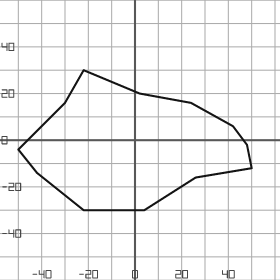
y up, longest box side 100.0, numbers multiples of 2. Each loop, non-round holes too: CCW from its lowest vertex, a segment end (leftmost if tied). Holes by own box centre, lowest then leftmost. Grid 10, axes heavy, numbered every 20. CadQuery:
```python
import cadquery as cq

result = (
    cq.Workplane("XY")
    .moveTo(-22.0, -30.0)
    .lineTo(4.0, -30.0)
    .lineTo(26.0, -16.0)
    .lineTo(50.0, -12.0)
    .lineTo(48.0, -2.0)
    .lineTo(42.0, 6.0)
    .lineTo(24.0, 16.0)
    .lineTo(2.0, 20.0)
    .lineTo(-22.0, 30.0)
    .lineTo(-30.0, 16.0)
    .lineTo(-50.0, -4.0)
    .lineTo(-42.0, -14.0)
    .close()
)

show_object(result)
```